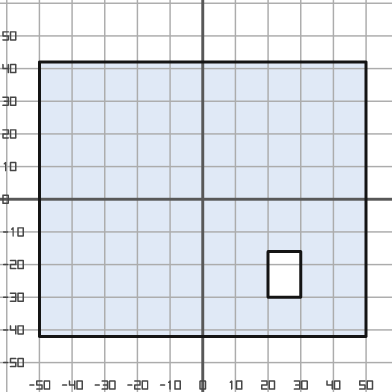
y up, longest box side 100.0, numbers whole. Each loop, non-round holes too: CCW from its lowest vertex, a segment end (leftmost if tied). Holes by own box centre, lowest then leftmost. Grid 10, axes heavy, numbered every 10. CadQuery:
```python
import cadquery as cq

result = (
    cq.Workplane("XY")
    .moveTo(-50.0, -42.0)
    .lineTo(50.0, -42.0)
    .lineTo(50.0, 42.0)
    .lineTo(-50.0, 42.0)
    .close()
    .moveTo(20.0, -30.0)
    .lineTo(30.0, -30.0)
    .lineTo(30.0, -16.0)
    .lineTo(20.0, -16.0)
    .close()
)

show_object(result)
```